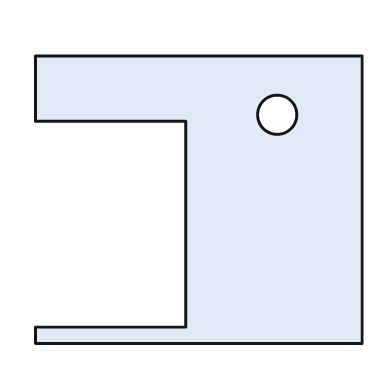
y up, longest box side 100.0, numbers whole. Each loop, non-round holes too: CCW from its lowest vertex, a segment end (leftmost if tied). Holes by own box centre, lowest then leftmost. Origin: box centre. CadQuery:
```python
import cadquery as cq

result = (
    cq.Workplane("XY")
    .moveTo(-50.0, -44.0)
    .lineTo(50.0, -44.0)
    .lineTo(50.0, 44.0)
    .lineTo(-50.0, 44.0)
    .lineTo(-50.0, 24.0)
    .lineTo(-4.0, 24.0)
    .lineTo(-4.0, -39.0)
    .lineTo(-50.0, -39.0)
    .close()
    .moveTo(24.0, 26.0)
    .circle(6.0)
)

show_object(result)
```